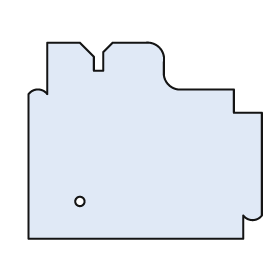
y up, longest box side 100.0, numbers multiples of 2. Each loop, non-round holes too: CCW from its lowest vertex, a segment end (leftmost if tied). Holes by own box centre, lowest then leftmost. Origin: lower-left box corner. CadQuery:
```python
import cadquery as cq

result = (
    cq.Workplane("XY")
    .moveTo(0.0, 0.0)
    .lineTo(92.0, 0.0)
    .lineTo(92.0, 10.0)
    .threePointArc((96.0, 8.0), (100.0, 10.0))
    .lineTo(100.0, 54.0)
    .lineTo(88.0, 54.0)
    .lineTo(88.0, 64.0)
    .lineTo(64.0, 64.0)
    .threePointArc((60.0, 66.0), (58.0, 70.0))
    .lineTo(58.0, 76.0)
    .threePointArc((56.0, 82.0), (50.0, 84.0))
    .lineTo(36.0, 84.0)
    .lineTo(32.0, 80.0)
    .lineTo(32.0, 72.0)
    .lineTo(28.0, 72.0)
    .lineTo(28.0, 78.0)
    .lineTo(22.0, 84.0)
    .lineTo(8.0, 84.0)
    .lineTo(8.0, 62.0)
    .threePointArc((4.0, 64.0), (0.0, 62.0))
    .close()
    .moveTo(22.0, 16.0)
    .circle(2.0)
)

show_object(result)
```